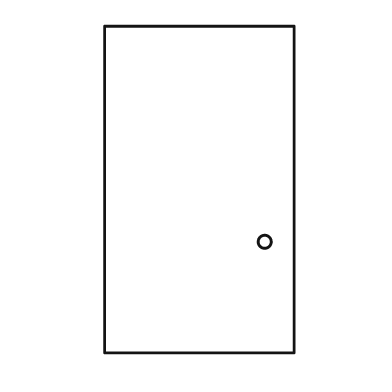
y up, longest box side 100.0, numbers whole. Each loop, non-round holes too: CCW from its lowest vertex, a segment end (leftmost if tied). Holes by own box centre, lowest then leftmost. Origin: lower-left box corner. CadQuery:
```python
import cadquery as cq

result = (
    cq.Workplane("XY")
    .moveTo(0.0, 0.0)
    .lineTo(58.0, 0.0)
    .lineTo(58.0, 100.0)
    .lineTo(0.0, 100.0)
    .close()
    .moveTo(49.0, 34.0)
    .circle(2.0)
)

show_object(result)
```